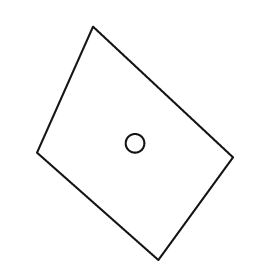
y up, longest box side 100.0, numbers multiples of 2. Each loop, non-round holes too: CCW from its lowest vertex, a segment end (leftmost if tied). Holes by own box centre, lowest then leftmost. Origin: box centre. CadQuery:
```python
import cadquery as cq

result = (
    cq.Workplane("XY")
    .moveTo(10.0, -50.0)
    .lineTo(42.0, -6.0)
    .lineTo(-18.0, 50.0)
    .lineTo(-42.0, -4.0)
    .close()
    .moveTo(0.0, 0.0)
    .circle(4.0)
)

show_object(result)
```